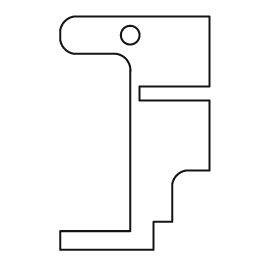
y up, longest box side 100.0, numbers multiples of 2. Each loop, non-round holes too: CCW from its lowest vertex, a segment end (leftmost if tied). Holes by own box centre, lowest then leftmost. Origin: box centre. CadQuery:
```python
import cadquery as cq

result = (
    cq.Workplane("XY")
    .moveTo(-32.0, -50.0)
    .lineTo(8.0, -50.0)
    .lineTo(8.0, -38.0)
    .lineTo(16.0, -38.0)
    .lineTo(16.0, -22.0)
    .threePointArc((18.0, -18.0), (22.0, -16.0))
    .lineTo(32.0, -16.0)
    .lineTo(32.0, 14.0)
    .lineTo(2.0, 14.0)
    .lineTo(2.0, 20.0)
    .lineTo(32.0, 20.0)
    .lineTo(32.0, 50.0)
    .lineTo(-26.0, 50.0)
    .threePointArc((-30.0, 48.0), (-32.0, 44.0))
    .lineTo(-32.0, 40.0)
    .threePointArc((-30.0, 36.0), (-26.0, 34.0))
    .lineTo(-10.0, 34.0)
    .threePointArc((-4.0, 32.0), (-2.0, 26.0))
    .lineTo(-2.0, -42.0)
    .lineTo(-32.0, -42.0)
    .close()
    .moveTo(-2.0, 42.0)
    .circle(4.0)
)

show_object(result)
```